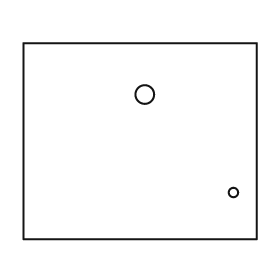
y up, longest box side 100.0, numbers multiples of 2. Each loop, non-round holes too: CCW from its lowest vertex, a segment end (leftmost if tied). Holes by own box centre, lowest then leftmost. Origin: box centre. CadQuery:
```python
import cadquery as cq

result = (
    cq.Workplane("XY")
    .moveTo(-50.0, -42.0)
    .lineTo(50.0, -42.0)
    .lineTo(50.0, 42.0)
    .lineTo(-50.0, 42.0)
    .close()
    .moveTo(40.0, -22.0)
    .circle(2.0)
    .moveTo(2.0, 20.0)
    .circle(4.0)
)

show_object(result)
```